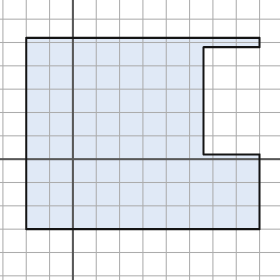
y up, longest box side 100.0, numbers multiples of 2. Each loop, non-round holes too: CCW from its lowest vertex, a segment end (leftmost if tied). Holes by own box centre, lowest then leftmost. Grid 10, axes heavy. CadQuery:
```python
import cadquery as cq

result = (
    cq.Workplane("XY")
    .moveTo(-20.0, -30.0)
    .lineTo(80.0, -30.0)
    .lineTo(80.0, 2.0)
    .lineTo(56.0, 2.0)
    .lineTo(56.0, 48.0)
    .lineTo(80.0, 48.0)
    .lineTo(80.0, 52.0)
    .lineTo(-20.0, 52.0)
    .close()
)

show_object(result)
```